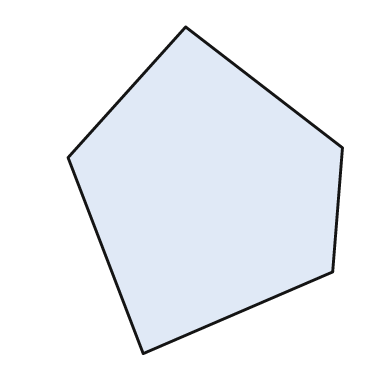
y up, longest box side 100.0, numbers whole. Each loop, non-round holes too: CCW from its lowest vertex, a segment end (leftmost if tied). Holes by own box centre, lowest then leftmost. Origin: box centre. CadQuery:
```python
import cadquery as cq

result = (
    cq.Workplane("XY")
    .moveTo(-19.0, -50.0)
    .lineTo(39.0, -25.0)
    .lineTo(42.0, 13.0)
    .lineTo(-6.0, 50.0)
    .lineTo(-42.0, 10.0)
    .close()
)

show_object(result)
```